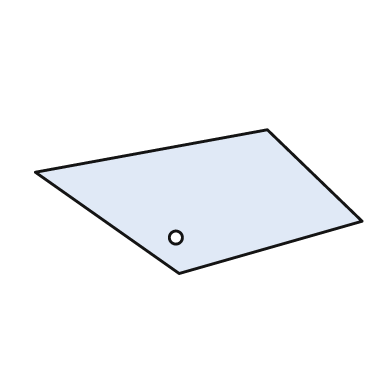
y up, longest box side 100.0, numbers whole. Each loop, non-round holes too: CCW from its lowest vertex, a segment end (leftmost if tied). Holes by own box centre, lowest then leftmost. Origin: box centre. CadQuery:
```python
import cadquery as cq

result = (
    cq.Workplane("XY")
    .moveTo(-6.0, -22.0)
    .lineTo(50.0, -6.0)
    .lineTo(21.0, 22.0)
    .lineTo(-50.0, 9.0)
    .close()
    .moveTo(-7.0, -11.0)
    .circle(2.0)
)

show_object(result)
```